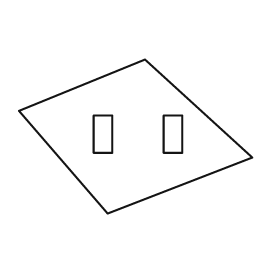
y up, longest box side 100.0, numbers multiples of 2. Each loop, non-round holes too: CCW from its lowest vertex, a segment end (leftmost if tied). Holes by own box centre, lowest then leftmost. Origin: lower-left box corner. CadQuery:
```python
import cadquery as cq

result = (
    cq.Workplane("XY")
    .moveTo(38.0, 0.0)
    .lineTo(100.0, 24.0)
    .lineTo(54.0, 66.0)
    .lineTo(0.0, 44.0)
    .close()
    .moveTo(32.0, 26.0)
    .lineTo(40.0, 26.0)
    .lineTo(40.0, 42.0)
    .lineTo(32.0, 42.0)
    .close()
    .moveTo(62.0, 26.0)
    .lineTo(70.0, 26.0)
    .lineTo(70.0, 42.0)
    .lineTo(62.0, 42.0)
    .close()
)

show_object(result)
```